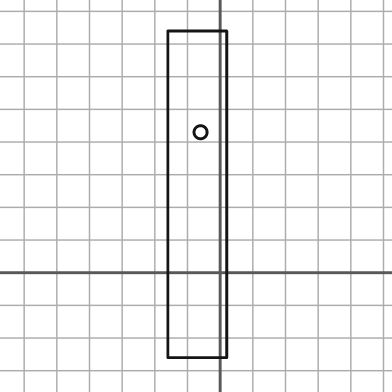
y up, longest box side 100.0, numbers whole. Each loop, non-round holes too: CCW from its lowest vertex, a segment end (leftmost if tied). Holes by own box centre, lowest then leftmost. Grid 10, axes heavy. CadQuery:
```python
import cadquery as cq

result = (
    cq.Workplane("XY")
    .moveTo(-16.0, -26.0)
    .lineTo(2.0, -26.0)
    .lineTo(2.0, 74.0)
    .lineTo(-16.0, 74.0)
    .close()
    .moveTo(-6.0, 43.0)
    .circle(2.0)
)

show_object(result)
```